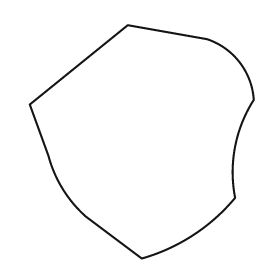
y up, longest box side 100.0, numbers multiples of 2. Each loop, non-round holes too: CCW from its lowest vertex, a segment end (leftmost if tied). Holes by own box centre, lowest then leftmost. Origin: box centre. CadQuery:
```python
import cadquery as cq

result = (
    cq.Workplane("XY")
    .moveTo(0.0, -50.0)
    .threePointArc((22.0, -40.0), (40.0, -24.0))
    .threePointArc((40.0, -2.0), (48.0, 18.0))
    .threePointArc((42.0, 34.0), (28.0, 44.0))
    .lineTo(-6.0, 50.0)
    .lineTo(-48.0, 16.0)
    .lineTo(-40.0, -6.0)
    .threePointArc((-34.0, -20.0), (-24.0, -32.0))
    .close()
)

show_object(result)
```